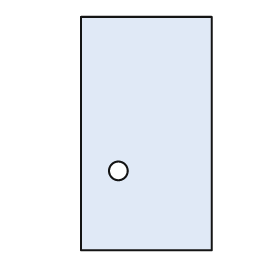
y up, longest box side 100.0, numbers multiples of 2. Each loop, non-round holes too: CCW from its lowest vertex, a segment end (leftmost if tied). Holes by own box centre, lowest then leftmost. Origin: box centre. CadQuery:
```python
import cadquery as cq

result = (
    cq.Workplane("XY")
    .moveTo(-28.0, -50.0)
    .lineTo(28.0, -50.0)
    .lineTo(28.0, 50.0)
    .lineTo(-28.0, 50.0)
    .close()
    .moveTo(-12.0, -16.0)
    .circle(4.0)
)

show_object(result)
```